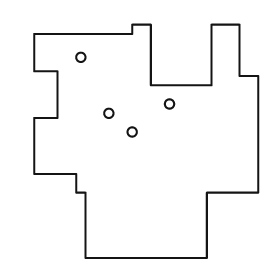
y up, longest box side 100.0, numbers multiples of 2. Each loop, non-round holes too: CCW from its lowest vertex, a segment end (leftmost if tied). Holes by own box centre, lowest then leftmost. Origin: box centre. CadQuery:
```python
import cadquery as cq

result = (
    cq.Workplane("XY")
    .moveTo(-26.0, -50.0)
    .lineTo(26.0, -50.0)
    .lineTo(26.0, -22.0)
    .lineTo(48.0, -22.0)
    .lineTo(48.0, 28.0)
    .lineTo(40.0, 28.0)
    .lineTo(40.0, 50.0)
    .lineTo(28.0, 50.0)
    .lineTo(28.0, 24.0)
    .lineTo(2.0, 24.0)
    .lineTo(2.0, 50.0)
    .lineTo(-6.0, 50.0)
    .lineTo(-6.0, 46.0)
    .lineTo(-48.0, 46.0)
    .lineTo(-48.0, 30.0)
    .lineTo(-38.0, 30.0)
    .lineTo(-38.0, 10.0)
    .lineTo(-48.0, 10.0)
    .lineTo(-48.0, -14.0)
    .lineTo(-30.0, -14.0)
    .lineTo(-30.0, -22.0)
    .lineTo(-26.0, -22.0)
    .close()
    .moveTo(-6.0, 4.0)
    .circle(2.0)
    .moveTo(-16.0, 12.0)
    .circle(2.0)
    .moveTo(10.0, 16.0)
    .circle(2.0)
    .moveTo(-28.0, 36.0)
    .circle(2.0)
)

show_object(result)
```